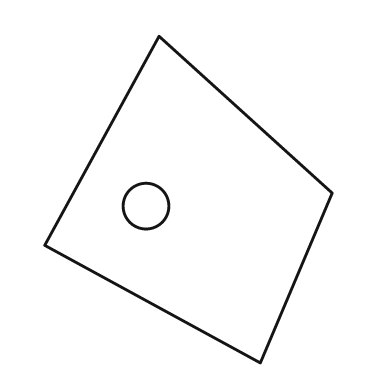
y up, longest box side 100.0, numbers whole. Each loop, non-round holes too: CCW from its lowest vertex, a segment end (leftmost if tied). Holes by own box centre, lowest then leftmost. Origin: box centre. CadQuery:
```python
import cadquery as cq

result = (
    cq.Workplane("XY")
    .moveTo(22.0, -50.0)
    .lineTo(44.0, 2.0)
    .lineTo(-9.0, 50.0)
    .lineTo(-44.0, -14.0)
    .close()
    .moveTo(-13.0, -2.0)
    .circle(7.0)
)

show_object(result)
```